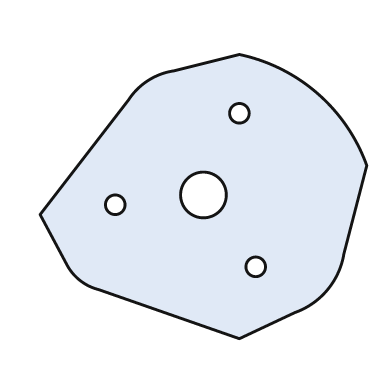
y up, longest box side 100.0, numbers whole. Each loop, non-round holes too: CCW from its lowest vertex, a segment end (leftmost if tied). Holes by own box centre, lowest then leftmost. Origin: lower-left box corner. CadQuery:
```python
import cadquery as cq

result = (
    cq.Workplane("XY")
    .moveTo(61.0, 0.0)
    .lineTo(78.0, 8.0)
    .threePointArc((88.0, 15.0), (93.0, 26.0))
    .lineTo(100.0, 53.0)
    .threePointArc((85.0, 75.0), (61.0, 87.0))
    .lineTo(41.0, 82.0)
    .threePointArc((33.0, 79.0), (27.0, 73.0))
    .lineTo(0.0, 38.0)
    .lineTo(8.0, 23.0)
    .threePointArc((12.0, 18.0), (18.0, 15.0))
    .close()
    .moveTo(66.0, 22.0)
    .circle(3.0)
    .moveTo(23.0, 41.0)
    .circle(3.0)
    .moveTo(50.0, 44.0)
    .circle(7.0)
    .moveTo(61.0, 69.0)
    .circle(3.0)
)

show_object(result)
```